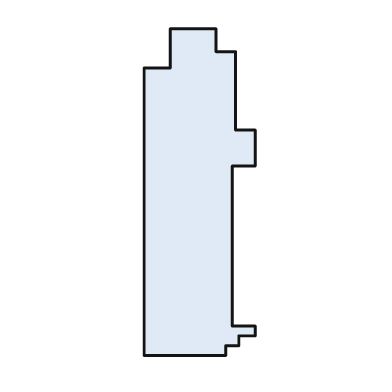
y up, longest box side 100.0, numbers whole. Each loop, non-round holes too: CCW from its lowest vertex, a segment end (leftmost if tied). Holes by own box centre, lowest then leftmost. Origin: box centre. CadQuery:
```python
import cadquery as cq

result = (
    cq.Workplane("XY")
    .moveTo(-17.0, -50.0)
    .lineTo(8.0, -50.0)
    .lineTo(8.0, -47.0)
    .lineTo(12.0, -47.0)
    .lineTo(12.0, -44.0)
    .lineTo(17.0, -44.0)
    .lineTo(17.0, -41.0)
    .lineTo(10.0, -41.0)
    .lineTo(10.0, 8.0)
    .lineTo(17.0, 8.0)
    .lineTo(17.0, 19.0)
    .lineTo(11.0, 19.0)
    .lineTo(11.0, 43.0)
    .lineTo(5.0, 43.0)
    .lineTo(5.0, 50.0)
    .lineTo(-9.0, 50.0)
    .lineTo(-9.0, 38.0)
    .lineTo(-17.0, 38.0)
    .close()
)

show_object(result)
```